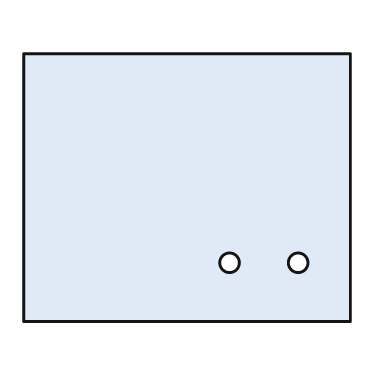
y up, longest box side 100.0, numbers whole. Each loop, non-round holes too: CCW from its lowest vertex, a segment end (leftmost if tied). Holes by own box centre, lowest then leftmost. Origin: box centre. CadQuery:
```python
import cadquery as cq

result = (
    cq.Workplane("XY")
    .moveTo(-50.0, -41.0)
    .lineTo(50.0, -41.0)
    .lineTo(50.0, 41.0)
    .lineTo(-50.0, 41.0)
    .close()
    .moveTo(13.0, -23.0)
    .circle(3.0)
    .moveTo(34.0, -23.0)
    .circle(3.0)
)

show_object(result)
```